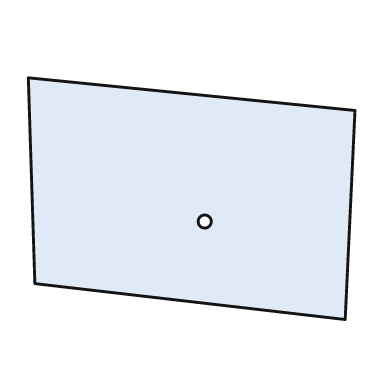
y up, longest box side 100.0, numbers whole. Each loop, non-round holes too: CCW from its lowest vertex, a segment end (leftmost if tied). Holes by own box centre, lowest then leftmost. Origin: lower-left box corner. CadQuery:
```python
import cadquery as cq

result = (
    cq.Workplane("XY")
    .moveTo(97.0, 0.0)
    .lineTo(100.0, 64.0)
    .lineTo(0.0, 74.0)
    .lineTo(2.0, 11.0)
    .close()
    .moveTo(54.0, 30.0)
    .circle(2.0)
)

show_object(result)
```